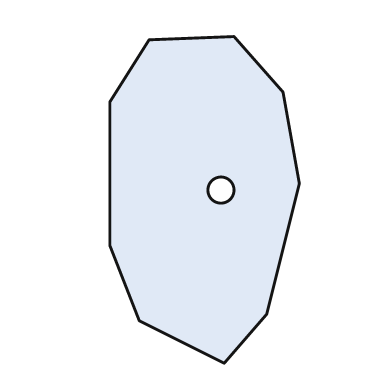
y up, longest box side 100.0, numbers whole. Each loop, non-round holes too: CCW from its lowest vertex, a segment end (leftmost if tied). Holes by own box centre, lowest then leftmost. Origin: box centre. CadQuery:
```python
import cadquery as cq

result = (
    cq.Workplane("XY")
    .moveTo(6.0, -50.0)
    .lineTo(19.0, -35.0)
    .lineTo(29.0, 5.0)
    .lineTo(24.0, 33.0)
    .lineTo(9.0, 50.0)
    .lineTo(-17.0, 49.0)
    .lineTo(-29.0, 30.0)
    .lineTo(-29.0, -14.0)
    .lineTo(-20.0, -37.0)
    .close()
    .moveTo(5.0, 3.0)
    .circle(4.0)
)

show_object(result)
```